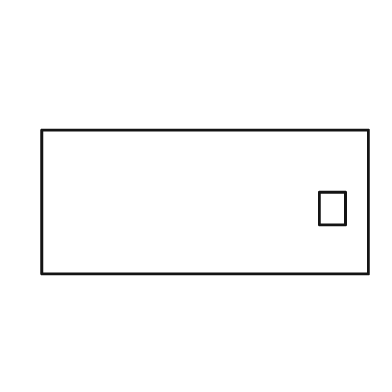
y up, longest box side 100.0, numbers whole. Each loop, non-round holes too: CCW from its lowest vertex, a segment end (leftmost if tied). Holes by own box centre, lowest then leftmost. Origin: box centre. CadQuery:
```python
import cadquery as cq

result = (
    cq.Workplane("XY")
    .moveTo(-50.0, -22.0)
    .lineTo(50.0, -22.0)
    .lineTo(50.0, 22.0)
    .lineTo(-50.0, 22.0)
    .close()
    .moveTo(35.0, -7.0)
    .lineTo(43.0, -7.0)
    .lineTo(43.0, 3.0)
    .lineTo(35.0, 3.0)
    .close()
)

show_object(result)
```